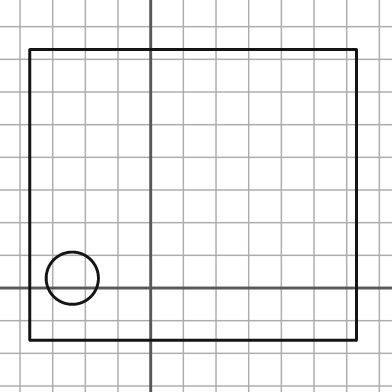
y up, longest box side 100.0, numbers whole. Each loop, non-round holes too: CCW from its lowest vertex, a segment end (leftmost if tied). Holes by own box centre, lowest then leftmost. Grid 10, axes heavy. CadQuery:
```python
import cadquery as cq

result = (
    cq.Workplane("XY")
    .moveTo(-37.0, -16.0)
    .lineTo(63.0, -16.0)
    .lineTo(63.0, 73.0)
    .lineTo(-37.0, 73.0)
    .close()
    .moveTo(-24.0, 3.0)
    .circle(8.0)
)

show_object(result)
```